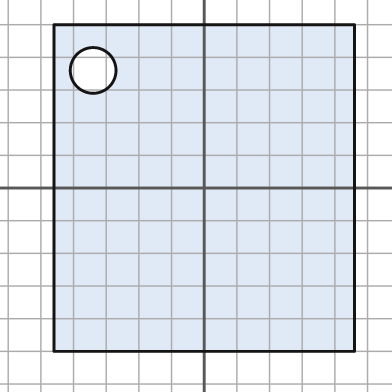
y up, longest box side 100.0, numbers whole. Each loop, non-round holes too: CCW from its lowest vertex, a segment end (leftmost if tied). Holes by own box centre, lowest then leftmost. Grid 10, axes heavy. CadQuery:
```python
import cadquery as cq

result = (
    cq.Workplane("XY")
    .moveTo(-46.0, -50.0)
    .lineTo(46.0, -50.0)
    .lineTo(46.0, 50.0)
    .lineTo(-46.0, 50.0)
    .close()
    .moveTo(-34.0, 36.0)
    .circle(7.0)
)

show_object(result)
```